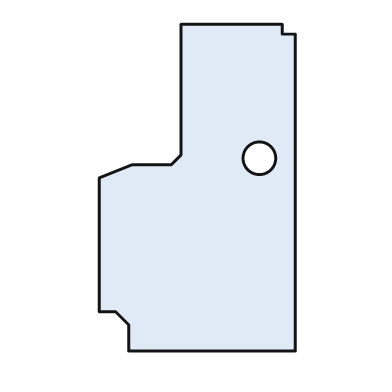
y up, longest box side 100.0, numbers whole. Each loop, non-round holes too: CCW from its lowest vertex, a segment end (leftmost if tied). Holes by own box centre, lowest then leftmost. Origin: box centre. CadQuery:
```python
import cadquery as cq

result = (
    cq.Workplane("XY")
    .moveTo(-21.0, -50.0)
    .lineTo(30.0, -50.0)
    .lineTo(30.0, 47.0)
    .lineTo(26.0, 47.0)
    .lineTo(26.0, 50.0)
    .lineTo(-5.0, 50.0)
    .lineTo(-5.0, 10.0)
    .lineTo(-8.0, 7.0)
    .lineTo(-20.0, 7.0)
    .lineTo(-30.0, 3.0)
    .lineTo(-30.0, -38.0)
    .lineTo(-25.0, -38.0)
    .lineTo(-21.0, -42.0)
    .close()
    .moveTo(19.0, 9.0)
    .circle(5.0)
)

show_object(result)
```